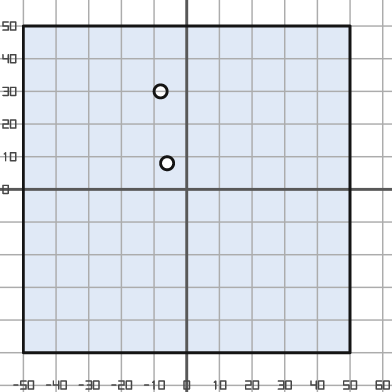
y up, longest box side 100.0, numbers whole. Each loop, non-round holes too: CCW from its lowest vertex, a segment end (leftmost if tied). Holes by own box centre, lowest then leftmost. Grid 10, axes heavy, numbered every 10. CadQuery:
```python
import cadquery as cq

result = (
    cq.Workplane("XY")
    .moveTo(-50.0, -50.0)
    .lineTo(50.0, -50.0)
    .lineTo(50.0, 50.0)
    .lineTo(-50.0, 50.0)
    .close()
    .moveTo(-6.0, 8.0)
    .circle(2.0)
    .moveTo(-8.0, 30.0)
    .circle(2.0)
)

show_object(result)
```